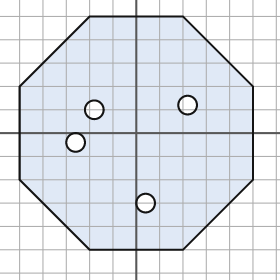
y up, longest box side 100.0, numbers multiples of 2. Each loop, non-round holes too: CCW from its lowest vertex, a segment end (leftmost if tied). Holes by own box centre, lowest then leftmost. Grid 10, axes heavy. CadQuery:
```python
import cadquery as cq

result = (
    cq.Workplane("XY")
    .moveTo(-20.0, -50.0)
    .lineTo(20.0, -50.0)
    .lineTo(50.0, -20.0)
    .lineTo(50.0, 20.0)
    .lineTo(20.0, 50.0)
    .lineTo(-20.0, 50.0)
    .lineTo(-50.0, 20.0)
    .lineTo(-50.0, -20.0)
    .close()
    .moveTo(4.0, -30.0)
    .circle(4.0)
    .moveTo(-26.0, -4.0)
    .circle(4.0)
    .moveTo(-18.0, 10.0)
    .circle(4.0)
    .moveTo(22.0, 12.0)
    .circle(4.0)
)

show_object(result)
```